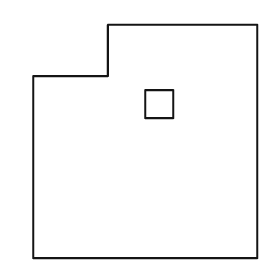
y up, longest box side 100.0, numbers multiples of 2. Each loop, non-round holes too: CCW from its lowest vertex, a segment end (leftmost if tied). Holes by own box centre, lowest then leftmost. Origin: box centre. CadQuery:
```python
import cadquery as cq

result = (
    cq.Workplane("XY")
    .moveTo(-48.0, -50.0)
    .lineTo(48.0, -50.0)
    .lineTo(48.0, 50.0)
    .lineTo(-16.0, 50.0)
    .lineTo(-16.0, 28.0)
    .lineTo(-48.0, 28.0)
    .close()
    .moveTo(0.0, 10.0)
    .lineTo(12.0, 10.0)
    .lineTo(12.0, 22.0)
    .lineTo(0.0, 22.0)
    .close()
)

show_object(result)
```